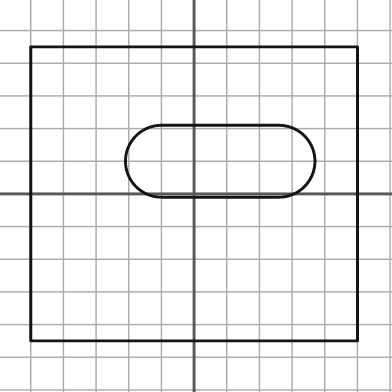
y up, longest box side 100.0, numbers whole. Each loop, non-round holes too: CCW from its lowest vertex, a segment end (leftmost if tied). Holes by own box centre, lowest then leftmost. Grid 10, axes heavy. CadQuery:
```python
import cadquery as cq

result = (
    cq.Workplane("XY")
    .moveTo(-50.0, -45.0)
    .lineTo(50.0, -45.0)
    .lineTo(50.0, 45.0)
    .lineTo(-50.0, 45.0)
    .close()
    .moveTo(-10.0, -1.0)
    .lineTo(26.0, -1.0)
    .threePointArc((37.0, 10.0), (26.0, 21.0))
    .lineTo(-10.0, 21.0)
    .threePointArc((-21.0, 10.0), (-10.0, -1.0))
    .close()
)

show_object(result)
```